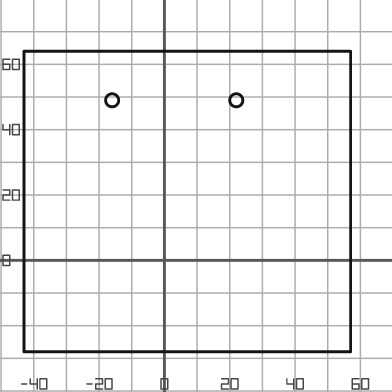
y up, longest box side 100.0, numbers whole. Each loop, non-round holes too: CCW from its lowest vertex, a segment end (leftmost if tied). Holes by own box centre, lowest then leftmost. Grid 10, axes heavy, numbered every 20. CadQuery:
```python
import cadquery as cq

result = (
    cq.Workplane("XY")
    .moveTo(-43.0, -28.0)
    .lineTo(57.0, -28.0)
    .lineTo(57.0, 64.0)
    .lineTo(-43.0, 64.0)
    .close()
    .moveTo(-16.0, 49.0)
    .circle(2.0)
    .moveTo(22.0, 49.0)
    .circle(2.0)
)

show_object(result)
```